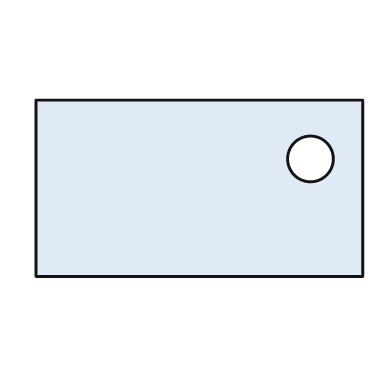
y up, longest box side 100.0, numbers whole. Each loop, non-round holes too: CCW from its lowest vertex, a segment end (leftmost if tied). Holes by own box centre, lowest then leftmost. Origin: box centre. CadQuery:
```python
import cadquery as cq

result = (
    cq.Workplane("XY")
    .moveTo(-50.0, -27.0)
    .lineTo(50.0, -27.0)
    .lineTo(50.0, 27.0)
    .lineTo(-50.0, 27.0)
    .close()
    .moveTo(34.0, 9.0)
    .circle(7.0)
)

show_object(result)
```